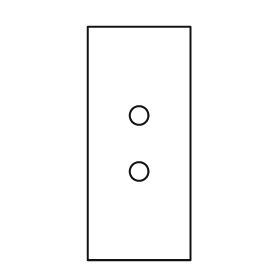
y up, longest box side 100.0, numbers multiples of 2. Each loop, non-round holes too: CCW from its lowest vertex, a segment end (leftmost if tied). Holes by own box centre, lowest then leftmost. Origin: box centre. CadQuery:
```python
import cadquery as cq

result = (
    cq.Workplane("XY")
    .moveTo(-22.0, -50.0)
    .lineTo(22.0, -50.0)
    .lineTo(22.0, 50.0)
    .lineTo(-22.0, 50.0)
    .close()
    .moveTo(0.0, -12.0)
    .circle(4.0)
    .moveTo(0.0, 12.0)
    .circle(4.0)
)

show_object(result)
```